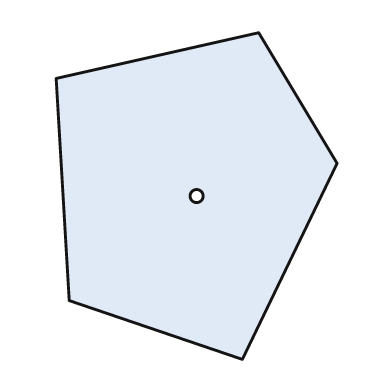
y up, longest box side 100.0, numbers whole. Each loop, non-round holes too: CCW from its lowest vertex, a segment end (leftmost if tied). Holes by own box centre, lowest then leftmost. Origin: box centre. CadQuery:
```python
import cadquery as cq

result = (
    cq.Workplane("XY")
    .moveTo(14.0, -50.0)
    .lineTo(43.0, 10.0)
    .lineTo(19.0, 50.0)
    .lineTo(-43.0, 36.0)
    .lineTo(-39.0, -32.0)
    .close()
    .moveTo(0.0, 0.0)
    .circle(2.0)
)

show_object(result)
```